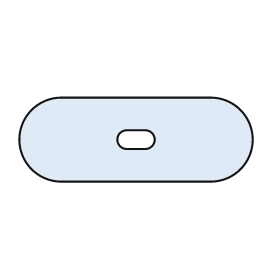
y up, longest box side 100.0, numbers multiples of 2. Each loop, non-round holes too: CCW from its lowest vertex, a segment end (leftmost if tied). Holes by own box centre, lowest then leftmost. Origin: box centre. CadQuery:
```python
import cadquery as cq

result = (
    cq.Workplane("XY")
    .moveTo(-32.0, -18.0)
    .lineTo(32.0, -18.0)
    .threePointArc((50.0, 0.0), (32.0, 18.0))
    .lineTo(-32.0, 18.0)
    .threePointArc((-50.0, 0.0), (-32.0, -18.0))
    .close()
    .moveTo(-4.0, -4.0)
    .lineTo(4.0, -4.0)
    .threePointArc((8.0, 0.0), (4.0, 4.0))
    .lineTo(-4.0, 4.0)
    .threePointArc((-8.0, 0.0), (-4.0, -4.0))
    .close()
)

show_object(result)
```